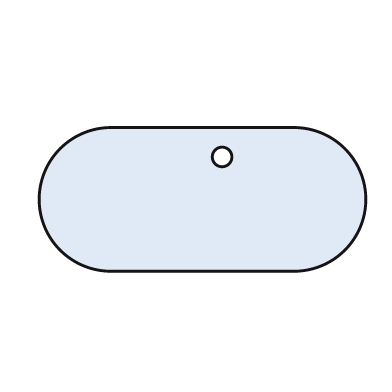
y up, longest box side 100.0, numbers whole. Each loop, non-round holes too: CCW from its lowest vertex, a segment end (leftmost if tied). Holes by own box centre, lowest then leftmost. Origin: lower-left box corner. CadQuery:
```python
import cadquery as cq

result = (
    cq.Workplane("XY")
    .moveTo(22.0, 0.0)
    .lineTo(78.0, 0.0)
    .threePointArc((100.0, 22.0), (78.0, 44.0))
    .lineTo(22.0, 44.0)
    .threePointArc((0.0, 22.0), (22.0, 0.0))
    .close()
    .moveTo(56.0, 35.0)
    .circle(3.0)
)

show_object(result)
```